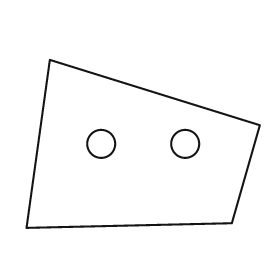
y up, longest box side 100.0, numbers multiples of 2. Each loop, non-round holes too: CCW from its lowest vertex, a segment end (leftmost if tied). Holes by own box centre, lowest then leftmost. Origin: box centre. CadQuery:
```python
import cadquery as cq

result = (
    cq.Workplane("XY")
    .moveTo(-50.0, -36.0)
    .lineTo(38.0, -34.0)
    .lineTo(50.0, 8.0)
    .lineTo(-40.0, 36.0)
    .close()
    .moveTo(-18.0, 0.0)
    .circle(6.0)
    .moveTo(18.0, 0.0)
    .circle(6.0)
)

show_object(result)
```